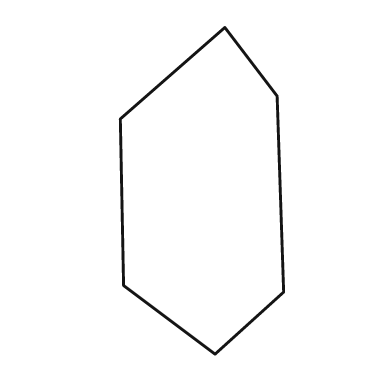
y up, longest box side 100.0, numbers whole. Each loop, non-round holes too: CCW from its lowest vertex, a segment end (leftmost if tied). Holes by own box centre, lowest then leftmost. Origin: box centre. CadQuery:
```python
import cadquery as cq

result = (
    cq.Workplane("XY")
    .moveTo(4.0, -50.0)
    .lineTo(25.0, -31.0)
    .lineTo(23.0, 29.0)
    .lineTo(7.0, 50.0)
    .lineTo(-25.0, 22.0)
    .lineTo(-24.0, -29.0)
    .close()
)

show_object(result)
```